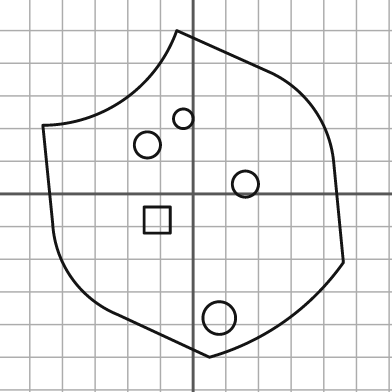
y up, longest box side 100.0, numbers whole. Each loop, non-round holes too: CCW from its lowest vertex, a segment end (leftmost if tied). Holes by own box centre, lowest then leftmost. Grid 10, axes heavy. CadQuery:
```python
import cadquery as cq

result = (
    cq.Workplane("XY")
    .moveTo(5.0, -50.0)
    .threePointArc((28.0, -39.0), (46.0, -21.0))
    .lineTo(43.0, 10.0)
    .threePointArc((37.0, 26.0), (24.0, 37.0))
    .lineTo(-5.0, 50.0)
    .threePointArc((-21.0, 29.0), (-46.0, 21.0))
    .lineTo(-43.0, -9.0)
    .threePointArc((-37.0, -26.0), (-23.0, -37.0))
    .close()
    .moveTo(8.0, -38.0)
    .circle(5.0)
    .moveTo(-15.0, -12.0)
    .lineTo(-7.0, -12.0)
    .lineTo(-7.0, -4.0)
    .lineTo(-15.0, -4.0)
    .close()
    .moveTo(16.0, 3.0)
    .circle(4.0)
    .moveTo(-14.0, 15.0)
    .circle(4.0)
    .moveTo(-3.0, 23.0)
    .circle(3.0)
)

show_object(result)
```